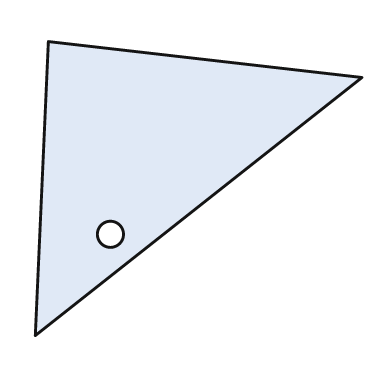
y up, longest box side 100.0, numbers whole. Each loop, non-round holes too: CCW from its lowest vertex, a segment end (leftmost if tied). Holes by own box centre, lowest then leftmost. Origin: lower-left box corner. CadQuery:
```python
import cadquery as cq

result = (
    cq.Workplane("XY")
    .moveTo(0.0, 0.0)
    .lineTo(100.0, 79.0)
    .lineTo(4.0, 90.0)
    .close()
    .moveTo(23.0, 31.0)
    .circle(4.0)
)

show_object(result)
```